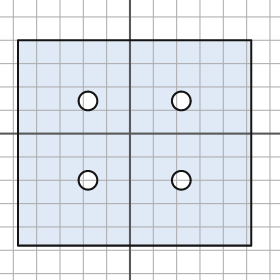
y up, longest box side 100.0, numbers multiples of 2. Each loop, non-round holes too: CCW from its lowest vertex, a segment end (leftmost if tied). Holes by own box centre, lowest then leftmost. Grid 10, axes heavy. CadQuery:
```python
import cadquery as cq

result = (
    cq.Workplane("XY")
    .moveTo(-48.0, -48.0)
    .lineTo(52.0, -48.0)
    .lineTo(52.0, 40.0)
    .lineTo(-48.0, 40.0)
    .close()
    .moveTo(-18.0, -20.0)
    .circle(4.0)
    .moveTo(22.0, -20.0)
    .circle(4.0)
    .moveTo(-18.0, 14.0)
    .circle(4.0)
    .moveTo(22.0, 14.0)
    .circle(4.0)
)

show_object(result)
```